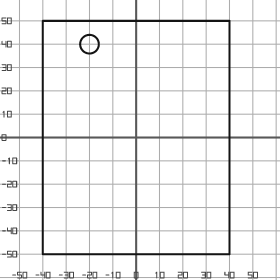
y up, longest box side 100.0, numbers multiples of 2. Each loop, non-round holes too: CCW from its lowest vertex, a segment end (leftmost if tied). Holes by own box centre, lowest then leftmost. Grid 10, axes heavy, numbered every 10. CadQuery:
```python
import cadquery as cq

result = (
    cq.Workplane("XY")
    .moveTo(-40.0, -50.0)
    .lineTo(40.0, -50.0)
    .lineTo(40.0, 50.0)
    .lineTo(-40.0, 50.0)
    .close()
    .moveTo(-20.0, 40.0)
    .circle(4.0)
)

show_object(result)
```